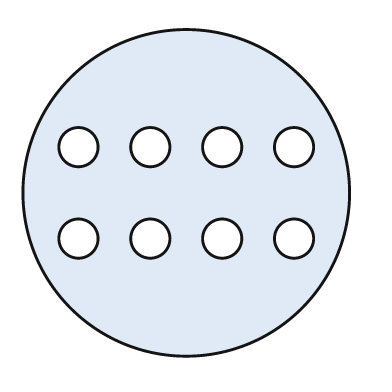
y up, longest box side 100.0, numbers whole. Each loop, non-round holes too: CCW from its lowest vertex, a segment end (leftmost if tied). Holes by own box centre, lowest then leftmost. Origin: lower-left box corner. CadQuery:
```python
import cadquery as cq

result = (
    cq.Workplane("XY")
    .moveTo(50.0, 50.0)
    .circle(50.0)
    .moveTo(17.0, 36.0)
    .circle(6.0)
    .moveTo(39.0, 36.0)
    .circle(6.0)
    .moveTo(61.0, 36.0)
    .circle(6.0)
    .moveTo(83.0, 36.0)
    .circle(6.0)
    .moveTo(17.0, 64.0)
    .circle(6.0)
    .moveTo(39.0, 64.0)
    .circle(6.0)
    .moveTo(61.0, 64.0)
    .circle(6.0)
    .moveTo(83.0, 64.0)
    .circle(6.0)
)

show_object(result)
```